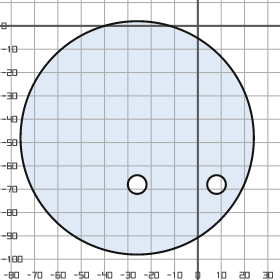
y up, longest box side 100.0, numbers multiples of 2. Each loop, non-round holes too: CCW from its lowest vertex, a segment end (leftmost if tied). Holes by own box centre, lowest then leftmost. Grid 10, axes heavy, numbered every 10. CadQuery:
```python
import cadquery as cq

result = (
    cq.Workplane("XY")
    .moveTo(-26.0, -48.0)
    .circle(50.0)
    .moveTo(-26.0, -68.0)
    .circle(4.0)
    .moveTo(8.0, -68.0)
    .circle(4.0)
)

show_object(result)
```